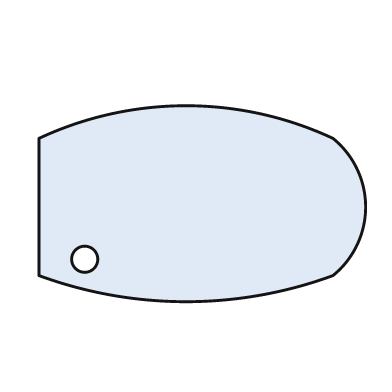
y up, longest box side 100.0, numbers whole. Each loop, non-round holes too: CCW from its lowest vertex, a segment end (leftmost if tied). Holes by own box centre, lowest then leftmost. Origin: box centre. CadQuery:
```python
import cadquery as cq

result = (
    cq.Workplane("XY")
    .moveTo(-50.0, -22.0)
    .threePointArc((-5.0, -30.0), (40.0, -22.0))
    .threePointArc((50.0, -1.0), (40.0, 20.0))
    .threePointArc((-5.0, 30.0), (-50.0, 20.0))
    .close()
    .moveTo(-36.0, -17.0)
    .circle(4.0)
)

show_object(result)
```